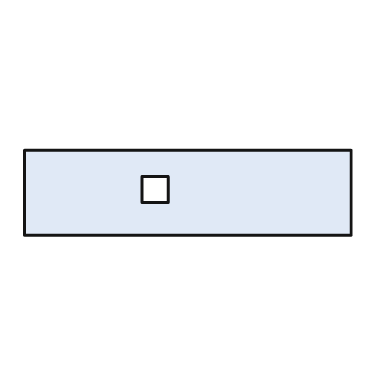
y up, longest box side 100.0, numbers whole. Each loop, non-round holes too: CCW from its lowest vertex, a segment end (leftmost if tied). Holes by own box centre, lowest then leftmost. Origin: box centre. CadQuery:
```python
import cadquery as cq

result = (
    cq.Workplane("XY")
    .moveTo(-50.0, -13.0)
    .lineTo(50.0, -13.0)
    .lineTo(50.0, 13.0)
    .lineTo(-50.0, 13.0)
    .close()
    .moveTo(-14.0, -3.0)
    .lineTo(-6.0, -3.0)
    .lineTo(-6.0, 5.0)
    .lineTo(-14.0, 5.0)
    .close()
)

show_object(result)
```